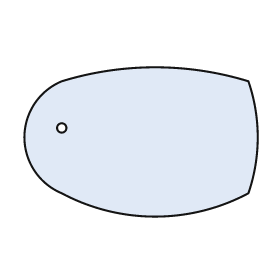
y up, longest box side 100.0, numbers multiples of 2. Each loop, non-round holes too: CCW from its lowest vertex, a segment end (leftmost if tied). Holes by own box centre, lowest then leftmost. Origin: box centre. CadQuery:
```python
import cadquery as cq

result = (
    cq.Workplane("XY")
    .moveTo(-34.0, -22.0)
    .threePointArc((6.0, -32.0), (46.0, -22.0))
    .threePointArc((50.0, 2.0), (46.0, 26.0))
    .threePointArc((6.0, 32.0), (-34.0, 26.0))
    .threePointArc((-50.0, 2.0), (-34.0, -22.0))
    .close()
    .moveTo(-34.0, 6.0)
    .circle(2.0)
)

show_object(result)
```